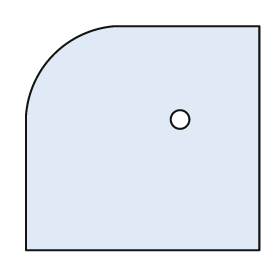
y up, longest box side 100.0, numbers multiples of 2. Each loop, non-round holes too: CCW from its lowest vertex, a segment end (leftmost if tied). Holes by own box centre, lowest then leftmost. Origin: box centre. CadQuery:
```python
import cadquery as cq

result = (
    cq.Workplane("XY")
    .moveTo(-50.0, -48.0)
    .lineTo(50.0, -48.0)
    .lineTo(50.0, 48.0)
    .lineTo(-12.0, 48.0)
    .threePointArc((-38.0, 36.0), (-50.0, 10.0))
    .close()
    .moveTo(16.0, 8.0)
    .circle(4.0)
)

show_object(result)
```